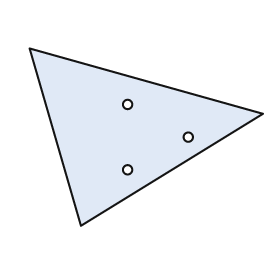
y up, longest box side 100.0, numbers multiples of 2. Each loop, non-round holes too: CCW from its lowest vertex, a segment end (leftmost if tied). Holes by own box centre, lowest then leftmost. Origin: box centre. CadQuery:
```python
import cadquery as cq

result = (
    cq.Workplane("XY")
    .moveTo(-28.0, -38.0)
    .lineTo(50.0, 10.0)
    .lineTo(-50.0, 38.0)
    .close()
    .moveTo(-8.0, -14.0)
    .circle(2.0)
    .moveTo(18.0, 0.0)
    .circle(2.0)
    .moveTo(-8.0, 14.0)
    .circle(2.0)
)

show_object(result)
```